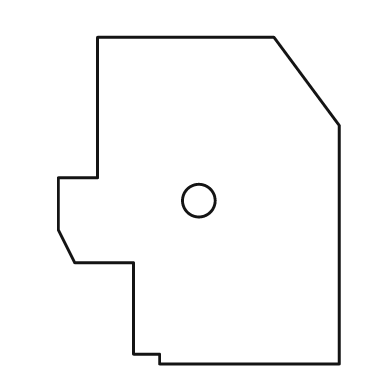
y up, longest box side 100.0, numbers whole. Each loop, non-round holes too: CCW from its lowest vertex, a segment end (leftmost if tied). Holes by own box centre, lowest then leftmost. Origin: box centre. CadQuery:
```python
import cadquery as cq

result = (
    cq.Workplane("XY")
    .moveTo(-12.0, -50.0)
    .lineTo(43.0, -50.0)
    .lineTo(43.0, 23.0)
    .lineTo(23.0, 50.0)
    .lineTo(-31.0, 50.0)
    .lineTo(-31.0, 7.0)
    .lineTo(-43.0, 7.0)
    .lineTo(-43.0, -9.0)
    .lineTo(-38.0, -19.0)
    .lineTo(-20.0, -19.0)
    .lineTo(-20.0, -47.0)
    .lineTo(-12.0, -47.0)
    .close()
    .moveTo(0.0, 0.0)
    .circle(5.0)
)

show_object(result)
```